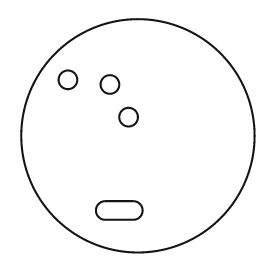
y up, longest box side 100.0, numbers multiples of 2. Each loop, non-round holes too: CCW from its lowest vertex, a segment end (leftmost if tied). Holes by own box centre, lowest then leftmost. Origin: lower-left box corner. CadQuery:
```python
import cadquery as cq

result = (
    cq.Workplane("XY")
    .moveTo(50.0, 50.0)
    .circle(50.0)
    .moveTo(36.0, 14.0)
    .lineTo(48.0, 14.0)
    .threePointArc((52.0, 18.0), (48.0, 22.0))
    .lineTo(36.0, 22.0)
    .threePointArc((32.0, 18.0), (36.0, 14.0))
    .close()
    .moveTo(46.0, 58.0)
    .circle(4.0)
    .moveTo(38.0, 72.0)
    .circle(4.0)
    .moveTo(20.0, 74.0)
    .circle(4.0)
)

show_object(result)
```